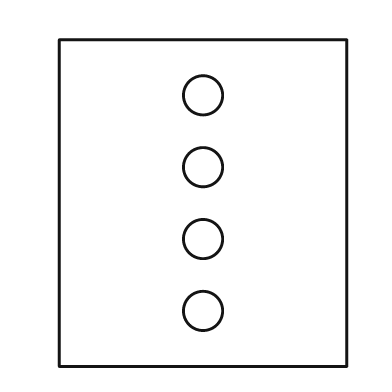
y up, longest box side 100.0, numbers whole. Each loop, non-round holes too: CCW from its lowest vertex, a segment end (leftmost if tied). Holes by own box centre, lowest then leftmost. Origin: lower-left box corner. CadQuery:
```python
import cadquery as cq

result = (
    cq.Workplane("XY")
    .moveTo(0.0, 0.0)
    .lineTo(88.0, 0.0)
    .lineTo(88.0, 100.0)
    .lineTo(0.0, 100.0)
    .close()
    .moveTo(44.0, 17.0)
    .circle(6.0)
    .moveTo(44.0, 39.0)
    .circle(6.0)
    .moveTo(44.0, 61.0)
    .circle(6.0)
    .moveTo(44.0, 83.0)
    .circle(6.0)
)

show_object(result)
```